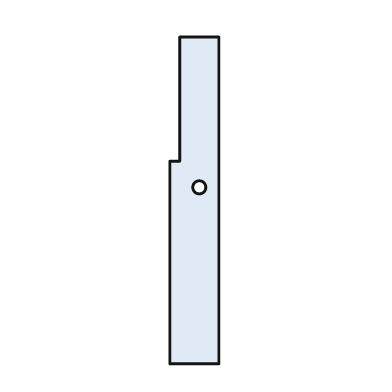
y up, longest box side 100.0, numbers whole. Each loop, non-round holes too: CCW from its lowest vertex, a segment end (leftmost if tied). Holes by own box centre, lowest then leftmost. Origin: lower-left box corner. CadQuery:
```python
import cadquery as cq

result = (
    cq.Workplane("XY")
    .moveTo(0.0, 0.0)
    .lineTo(15.0, 0.0)
    .lineTo(15.0, 100.0)
    .lineTo(3.0, 100.0)
    .lineTo(3.0, 62.0)
    .lineTo(0.0, 62.0)
    .close()
    .moveTo(9.0, 54.0)
    .circle(2.0)
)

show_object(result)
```